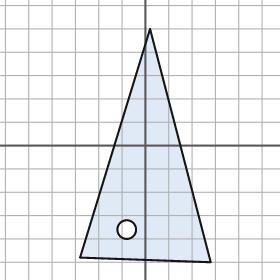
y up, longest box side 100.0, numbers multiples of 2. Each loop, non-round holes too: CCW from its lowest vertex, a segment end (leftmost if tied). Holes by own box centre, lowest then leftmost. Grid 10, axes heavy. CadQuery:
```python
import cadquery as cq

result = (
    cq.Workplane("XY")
    .moveTo(28.0, -50.0)
    .lineTo(2.0, 50.0)
    .lineTo(-28.0, -48.0)
    .close()
    .moveTo(-8.0, -36.0)
    .circle(4.0)
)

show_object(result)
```